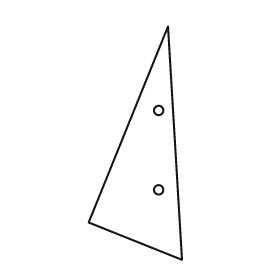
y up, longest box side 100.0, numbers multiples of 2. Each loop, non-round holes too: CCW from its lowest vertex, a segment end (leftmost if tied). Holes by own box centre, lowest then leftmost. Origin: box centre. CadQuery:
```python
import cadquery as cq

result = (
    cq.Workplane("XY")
    .moveTo(20.0, -50.0)
    .lineTo(14.0, 50.0)
    .lineTo(-20.0, -34.0)
    .close()
    .moveTo(10.0, -20.0)
    .circle(2.0)
    .moveTo(10.0, 14.0)
    .circle(2.0)
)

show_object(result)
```